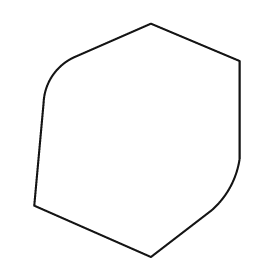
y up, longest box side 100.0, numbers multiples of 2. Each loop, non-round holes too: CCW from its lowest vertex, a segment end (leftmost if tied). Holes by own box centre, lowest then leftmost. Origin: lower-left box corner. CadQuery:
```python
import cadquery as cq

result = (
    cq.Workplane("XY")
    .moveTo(50.0, 0.0)
    .lineTo(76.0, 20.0)
    .threePointArc((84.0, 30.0), (88.0, 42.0))
    .lineTo(88.0, 84.0)
    .lineTo(50.0, 100.0)
    .lineTo(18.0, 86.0)
    .threePointArc((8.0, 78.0), (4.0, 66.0))
    .lineTo(0.0, 22.0)
    .close()
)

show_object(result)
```